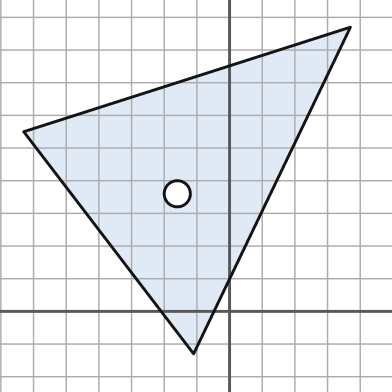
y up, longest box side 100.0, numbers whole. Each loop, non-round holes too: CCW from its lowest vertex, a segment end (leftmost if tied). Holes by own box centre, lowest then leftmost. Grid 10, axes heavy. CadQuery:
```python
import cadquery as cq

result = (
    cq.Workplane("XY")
    .moveTo(-11.0, -13.0)
    .lineTo(37.0, 87.0)
    .lineTo(-63.0, 55.0)
    .close()
    .moveTo(-16.0, 36.0)
    .circle(4.0)
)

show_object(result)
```